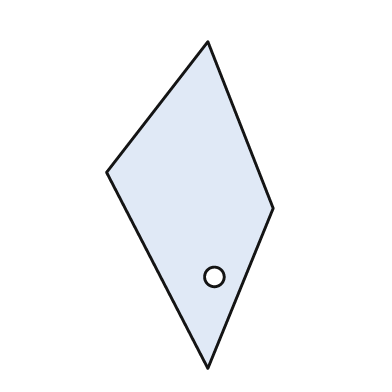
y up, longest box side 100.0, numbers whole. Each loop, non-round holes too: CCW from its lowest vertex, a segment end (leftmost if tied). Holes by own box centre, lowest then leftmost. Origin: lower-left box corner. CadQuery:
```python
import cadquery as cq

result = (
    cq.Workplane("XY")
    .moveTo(31.0, 0.0)
    .lineTo(51.0, 49.0)
    .lineTo(31.0, 100.0)
    .lineTo(0.0, 60.0)
    .close()
    .moveTo(33.0, 28.0)
    .circle(3.0)
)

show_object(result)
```